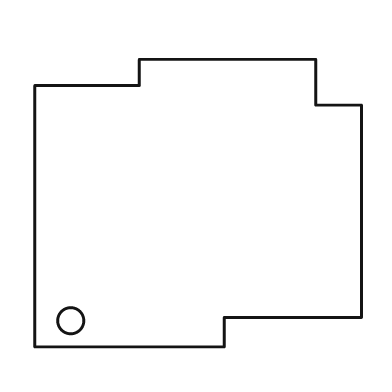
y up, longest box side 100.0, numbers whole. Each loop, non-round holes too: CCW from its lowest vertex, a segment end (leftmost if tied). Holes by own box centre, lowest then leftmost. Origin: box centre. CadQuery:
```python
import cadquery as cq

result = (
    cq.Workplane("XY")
    .moveTo(-50.0, -44.0)
    .lineTo(8.0, -44.0)
    .lineTo(8.0, -35.0)
    .lineTo(50.0, -35.0)
    .lineTo(50.0, 30.0)
    .lineTo(36.0, 30.0)
    .lineTo(36.0, 44.0)
    .lineTo(-18.0, 44.0)
    .lineTo(-18.0, 36.0)
    .lineTo(-50.0, 36.0)
    .close()
    .moveTo(-39.0, -36.0)
    .circle(4.0)
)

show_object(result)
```